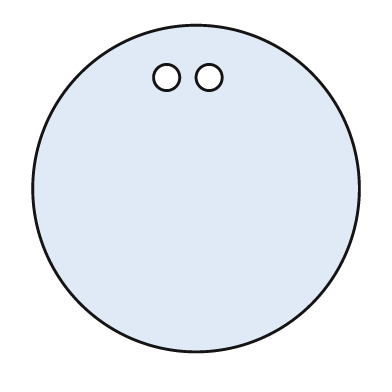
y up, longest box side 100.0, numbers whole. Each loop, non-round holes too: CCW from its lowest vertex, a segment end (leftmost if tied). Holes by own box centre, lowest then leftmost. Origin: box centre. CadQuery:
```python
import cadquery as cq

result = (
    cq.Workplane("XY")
    .moveTo(0.0, 0.0)
    .circle(50.0)
    .moveTo(-9.0, 34.0)
    .circle(4.0)
    .moveTo(4.0, 34.0)
    .circle(4.0)
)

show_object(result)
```